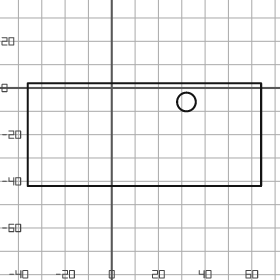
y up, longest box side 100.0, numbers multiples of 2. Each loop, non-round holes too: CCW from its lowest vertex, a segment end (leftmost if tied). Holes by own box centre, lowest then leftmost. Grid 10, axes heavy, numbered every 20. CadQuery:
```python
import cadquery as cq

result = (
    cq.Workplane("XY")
    .moveTo(-36.0, -42.0)
    .lineTo(64.0, -42.0)
    .lineTo(64.0, 2.0)
    .lineTo(-36.0, 2.0)
    .close()
    .moveTo(32.0, -6.0)
    .circle(4.0)
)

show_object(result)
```